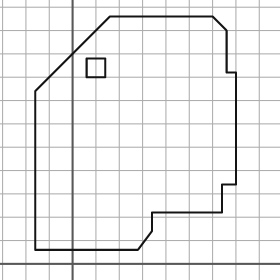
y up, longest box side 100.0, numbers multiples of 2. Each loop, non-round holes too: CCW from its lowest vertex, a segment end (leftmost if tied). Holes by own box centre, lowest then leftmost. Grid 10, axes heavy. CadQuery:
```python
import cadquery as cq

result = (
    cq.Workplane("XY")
    .moveTo(-16.0, 6.0)
    .lineTo(28.0, 6.0)
    .lineTo(34.0, 14.0)
    .lineTo(34.0, 22.0)
    .lineTo(64.0, 22.0)
    .lineTo(64.0, 34.0)
    .lineTo(70.0, 34.0)
    .lineTo(70.0, 82.0)
    .lineTo(66.0, 82.0)
    .lineTo(66.0, 100.0)
    .lineTo(60.0, 106.0)
    .lineTo(16.0, 106.0)
    .lineTo(-16.0, 74.0)
    .close()
    .moveTo(6.0, 80.0)
    .lineTo(14.0, 80.0)
    .lineTo(14.0, 88.0)
    .lineTo(6.0, 88.0)
    .close()
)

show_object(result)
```